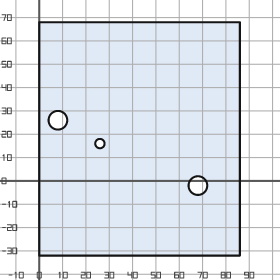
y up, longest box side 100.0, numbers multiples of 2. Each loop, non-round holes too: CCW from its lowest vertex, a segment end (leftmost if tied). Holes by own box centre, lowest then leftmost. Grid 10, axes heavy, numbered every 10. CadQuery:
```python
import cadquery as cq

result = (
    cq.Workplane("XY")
    .moveTo(0.0, -32.0)
    .lineTo(86.0, -32.0)
    .lineTo(86.0, 68.0)
    .lineTo(0.0, 68.0)
    .close()
    .moveTo(68.0, -2.0)
    .circle(4.0)
    .moveTo(26.0, 16.0)
    .circle(2.0)
    .moveTo(8.0, 26.0)
    .circle(4.0)
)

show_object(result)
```